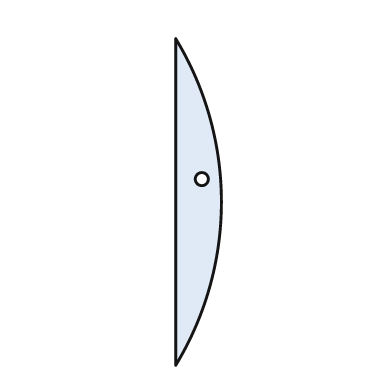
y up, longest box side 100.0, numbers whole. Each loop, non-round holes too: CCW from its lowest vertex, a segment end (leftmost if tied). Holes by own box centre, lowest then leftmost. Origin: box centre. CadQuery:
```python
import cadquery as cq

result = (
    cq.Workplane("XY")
    .moveTo(-7.0, -50.0)
    .threePointArc((7.0, 0.0), (-7.0, 50.0))
    .close()
    .moveTo(1.0, 7.0)
    .circle(2.0)
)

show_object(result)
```